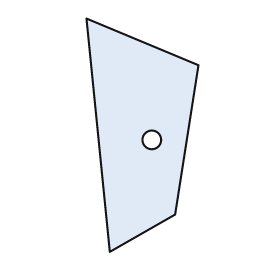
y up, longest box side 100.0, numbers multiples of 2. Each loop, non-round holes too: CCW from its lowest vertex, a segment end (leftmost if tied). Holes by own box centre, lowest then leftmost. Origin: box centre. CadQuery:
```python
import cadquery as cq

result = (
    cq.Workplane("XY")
    .moveTo(-14.0, -50.0)
    .lineTo(14.0, -34.0)
    .lineTo(24.0, 30.0)
    .lineTo(-24.0, 50.0)
    .close()
    .moveTo(4.0, -2.0)
    .circle(4.0)
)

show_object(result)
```